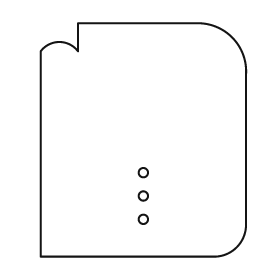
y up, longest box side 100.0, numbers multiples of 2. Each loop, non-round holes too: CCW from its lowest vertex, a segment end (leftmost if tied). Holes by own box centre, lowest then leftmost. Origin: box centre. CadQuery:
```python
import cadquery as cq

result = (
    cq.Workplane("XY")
    .moveTo(-44.0, -50.0)
    .lineTo(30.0, -50.0)
    .threePointArc((40.0, -46.0), (44.0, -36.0))
    .lineTo(44.0, 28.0)
    .threePointArc((38.0, 44.0), (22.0, 50.0))
    .lineTo(-28.0, 50.0)
    .lineTo(-28.0, 38.0)
    .threePointArc((-36.0, 42.0), (-44.0, 38.0))
    .close()
    .moveTo(0.0, -34.0)
    .circle(2.0)
    .moveTo(0.0, -24.0)
    .circle(2.0)
    .moveTo(0.0, -14.0)
    .circle(2.0)
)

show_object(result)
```